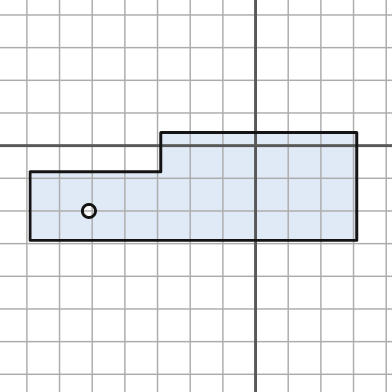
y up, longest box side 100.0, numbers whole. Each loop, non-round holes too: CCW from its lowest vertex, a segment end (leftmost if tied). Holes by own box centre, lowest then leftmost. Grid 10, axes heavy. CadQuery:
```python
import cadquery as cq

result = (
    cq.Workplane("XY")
    .moveTo(-69.0, -29.0)
    .lineTo(31.0, -29.0)
    .lineTo(31.0, 4.0)
    .lineTo(-29.0, 4.0)
    .lineTo(-29.0, -8.0)
    .lineTo(-69.0, -8.0)
    .close()
    .moveTo(-51.0, -20.0)
    .circle(2.0)
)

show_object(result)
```